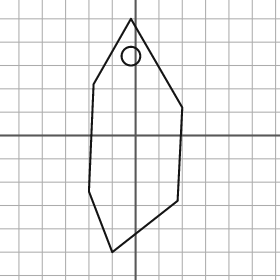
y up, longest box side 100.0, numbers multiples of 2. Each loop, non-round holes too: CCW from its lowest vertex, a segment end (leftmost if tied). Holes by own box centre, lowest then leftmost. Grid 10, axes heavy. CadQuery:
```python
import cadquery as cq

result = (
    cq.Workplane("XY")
    .moveTo(-10.0, -50.0)
    .lineTo(18.0, -28.0)
    .lineTo(20.0, 12.0)
    .lineTo(-2.0, 50.0)
    .lineTo(-18.0, 22.0)
    .lineTo(-20.0, -24.0)
    .close()
    .moveTo(-2.0, 34.0)
    .circle(4.0)
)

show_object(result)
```